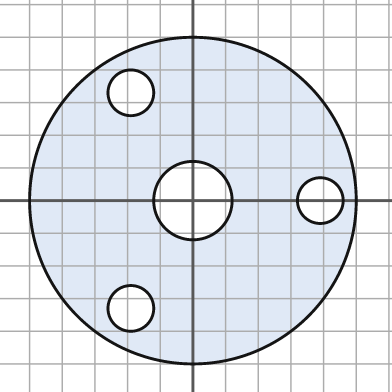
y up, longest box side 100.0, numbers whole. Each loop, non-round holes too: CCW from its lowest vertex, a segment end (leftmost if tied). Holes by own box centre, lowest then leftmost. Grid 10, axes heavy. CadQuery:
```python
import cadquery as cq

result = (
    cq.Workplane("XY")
    .moveTo(0.0, 0.0)
    .circle(50.0)
    .moveTo(-19.0, -33.0)
    .circle(7.0)
    .moveTo(0.0, 0.0)
    .circle(12.0)
    .moveTo(39.0, 0.0)
    .circle(7.0)
    .moveTo(-19.0, 33.0)
    .circle(7.0)
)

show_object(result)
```